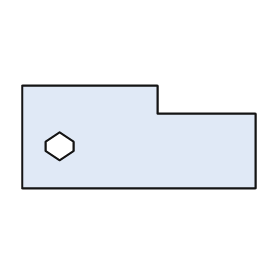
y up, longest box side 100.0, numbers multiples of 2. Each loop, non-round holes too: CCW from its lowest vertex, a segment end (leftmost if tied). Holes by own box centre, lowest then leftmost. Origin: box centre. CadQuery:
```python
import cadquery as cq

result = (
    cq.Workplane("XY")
    .moveTo(-50.0, -22.0)
    .lineTo(50.0, -22.0)
    .lineTo(50.0, 10.0)
    .lineTo(8.0, 10.0)
    .lineTo(8.0, 22.0)
    .lineTo(-50.0, 22.0)
    .close()
    .moveTo(-34.0, -10.0)
    .lineTo(-28.0, -6.0)
    .lineTo(-28.0, -2.0)
    .lineTo(-34.0, 2.0)
    .lineTo(-40.0, -2.0)
    .lineTo(-40.0, -6.0)
    .close()
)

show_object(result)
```